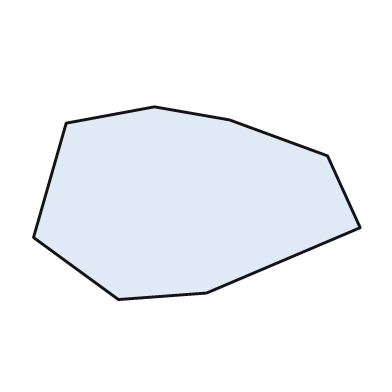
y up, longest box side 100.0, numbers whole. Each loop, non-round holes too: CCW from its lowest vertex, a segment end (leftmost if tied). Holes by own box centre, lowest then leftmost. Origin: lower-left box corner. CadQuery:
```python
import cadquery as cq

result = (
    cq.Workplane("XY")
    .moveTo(26.0, 0.0)
    .lineTo(53.0, 2.0)
    .lineTo(100.0, 22.0)
    .lineTo(90.0, 44.0)
    .lineTo(60.0, 55.0)
    .lineTo(37.0, 59.0)
    .lineTo(10.0, 54.0)
    .lineTo(0.0, 19.0)
    .close()
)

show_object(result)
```